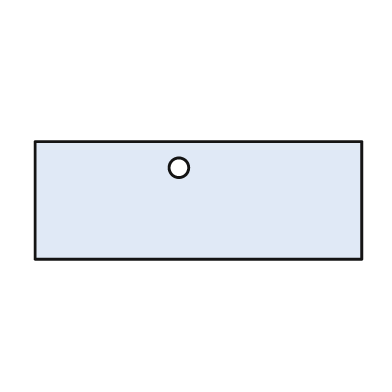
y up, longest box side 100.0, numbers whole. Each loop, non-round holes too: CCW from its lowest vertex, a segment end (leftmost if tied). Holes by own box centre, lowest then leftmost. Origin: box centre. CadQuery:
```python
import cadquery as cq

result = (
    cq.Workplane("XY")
    .moveTo(-50.0, -18.0)
    .lineTo(50.0, -18.0)
    .lineTo(50.0, 18.0)
    .lineTo(-50.0, 18.0)
    .close()
    .moveTo(-6.0, 10.0)
    .circle(3.0)
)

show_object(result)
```